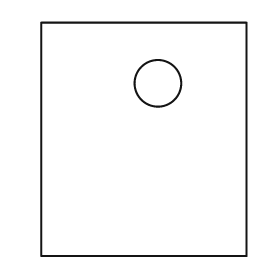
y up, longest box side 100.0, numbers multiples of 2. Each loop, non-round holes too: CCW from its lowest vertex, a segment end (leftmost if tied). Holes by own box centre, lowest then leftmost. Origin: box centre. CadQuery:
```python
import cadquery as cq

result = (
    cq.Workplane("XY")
    .moveTo(-44.0, -50.0)
    .lineTo(44.0, -50.0)
    .lineTo(44.0, 50.0)
    .lineTo(-44.0, 50.0)
    .close()
    .moveTo(6.0, 24.0)
    .circle(10.0)
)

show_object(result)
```